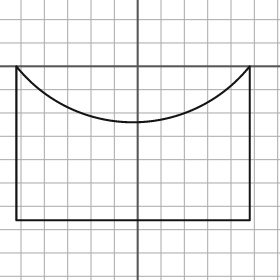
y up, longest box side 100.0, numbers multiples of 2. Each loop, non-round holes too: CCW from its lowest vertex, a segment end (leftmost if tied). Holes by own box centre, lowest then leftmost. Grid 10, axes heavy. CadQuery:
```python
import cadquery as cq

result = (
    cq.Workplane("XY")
    .moveTo(-52.0, -66.0)
    .lineTo(48.0, -66.0)
    .lineTo(48.0, 0.0)
    .threePointArc((-2.0, -24.0), (-52.0, 0.0))
    .close()
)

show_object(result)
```